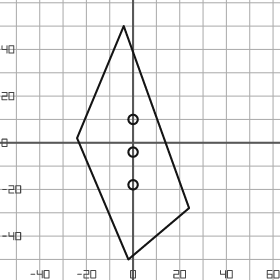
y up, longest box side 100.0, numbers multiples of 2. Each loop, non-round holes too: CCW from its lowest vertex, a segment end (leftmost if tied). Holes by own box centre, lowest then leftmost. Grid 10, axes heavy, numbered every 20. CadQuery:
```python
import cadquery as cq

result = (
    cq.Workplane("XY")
    .moveTo(-2.0, -50.0)
    .lineTo(24.0, -28.0)
    .lineTo(-4.0, 50.0)
    .lineTo(-24.0, 2.0)
    .close()
    .moveTo(0.0, -18.0)
    .circle(2.0)
    .moveTo(0.0, -4.0)
    .circle(2.0)
    .moveTo(0.0, 10.0)
    .circle(2.0)
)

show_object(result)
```